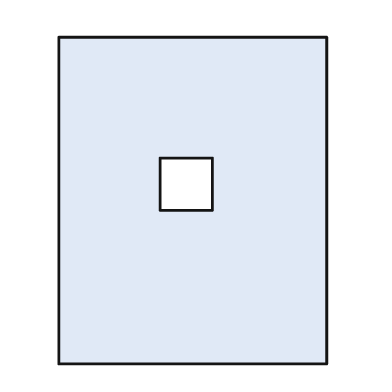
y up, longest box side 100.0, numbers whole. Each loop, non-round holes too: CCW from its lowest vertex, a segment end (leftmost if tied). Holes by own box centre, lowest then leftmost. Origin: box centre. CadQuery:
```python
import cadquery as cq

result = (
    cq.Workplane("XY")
    .moveTo(-41.0, -50.0)
    .lineTo(41.0, -50.0)
    .lineTo(41.0, 50.0)
    .lineTo(-41.0, 50.0)
    .close()
    .moveTo(-10.0, -3.0)
    .lineTo(6.0, -3.0)
    .lineTo(6.0, 13.0)
    .lineTo(-10.0, 13.0)
    .close()
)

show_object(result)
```